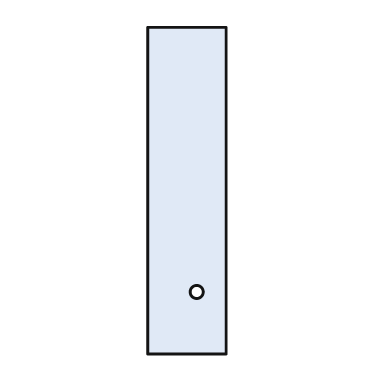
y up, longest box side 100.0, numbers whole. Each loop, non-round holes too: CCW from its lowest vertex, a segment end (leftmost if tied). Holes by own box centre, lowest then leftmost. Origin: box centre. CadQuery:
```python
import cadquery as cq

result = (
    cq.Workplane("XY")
    .moveTo(-12.0, -50.0)
    .lineTo(12.0, -50.0)
    .lineTo(12.0, 50.0)
    .lineTo(-12.0, 50.0)
    .close()
    .moveTo(3.0, -31.0)
    .circle(2.0)
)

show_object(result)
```